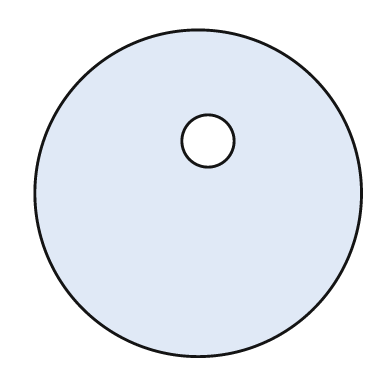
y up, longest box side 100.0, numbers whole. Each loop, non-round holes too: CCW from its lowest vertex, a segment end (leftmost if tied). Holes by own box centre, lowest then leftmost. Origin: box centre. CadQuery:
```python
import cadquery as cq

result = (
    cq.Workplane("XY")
    .moveTo(0.0, 0.0)
    .circle(50.0)
    .moveTo(3.0, 16.0)
    .circle(8.0)
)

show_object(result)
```